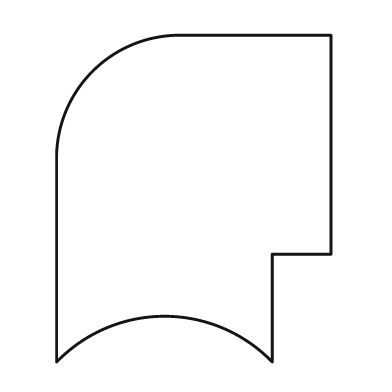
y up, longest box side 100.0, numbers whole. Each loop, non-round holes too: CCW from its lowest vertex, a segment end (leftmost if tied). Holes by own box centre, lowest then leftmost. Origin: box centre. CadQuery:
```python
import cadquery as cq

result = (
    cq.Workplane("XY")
    .moveTo(-42.0, -50.0)
    .threePointArc((-9.0, -36.0), (24.0, -50.0))
    .lineTo(24.0, -17.0)
    .lineTo(42.0, -17.0)
    .lineTo(42.0, 50.0)
    .lineTo(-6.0, 50.0)
    .threePointArc((-31.0, 39.0), (-42.0, 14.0))
    .close()
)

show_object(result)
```